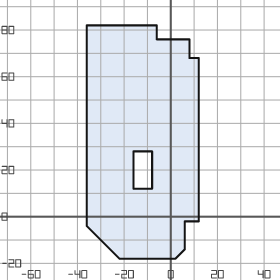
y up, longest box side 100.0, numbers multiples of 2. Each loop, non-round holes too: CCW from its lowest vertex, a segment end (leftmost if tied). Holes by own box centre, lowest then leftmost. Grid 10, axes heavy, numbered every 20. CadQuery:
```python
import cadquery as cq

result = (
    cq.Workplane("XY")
    .moveTo(-22.0, -18.0)
    .lineTo(2.0, -18.0)
    .lineTo(6.0, -14.0)
    .lineTo(6.0, -2.0)
    .lineTo(12.0, -2.0)
    .lineTo(12.0, 68.0)
    .lineTo(8.0, 68.0)
    .lineTo(8.0, 76.0)
    .lineTo(-6.0, 76.0)
    .lineTo(-6.0, 82.0)
    .lineTo(-36.0, 82.0)
    .lineTo(-36.0, -4.0)
    .close()
    .moveTo(-16.0, 12.0)
    .lineTo(-8.0, 12.0)
    .lineTo(-8.0, 28.0)
    .lineTo(-16.0, 28.0)
    .close()
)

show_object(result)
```